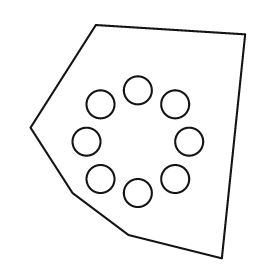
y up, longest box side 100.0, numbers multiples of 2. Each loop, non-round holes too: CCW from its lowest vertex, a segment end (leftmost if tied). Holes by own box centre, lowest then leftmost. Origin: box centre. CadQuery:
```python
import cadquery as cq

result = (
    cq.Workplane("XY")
    .moveTo(36.0, -50.0)
    .lineTo(46.0, 46.0)
    .lineTo(-18.0, 50.0)
    .lineTo(-46.0, 6.0)
    .lineTo(-28.0, -22.0)
    .lineTo(-4.0, -40.0)
    .close()
    .moveTo(0.0, -22.0)
    .circle(6.0)
    .moveTo(-16.0, -16.0)
    .circle(6.0)
    .moveTo(16.0, -16.0)
    .circle(6.0)
    .moveTo(-22.0, 0.0)
    .circle(6.0)
    .moveTo(22.0, 0.0)
    .circle(6.0)
    .moveTo(-16.0, 16.0)
    .circle(6.0)
    .moveTo(16.0, 16.0)
    .circle(6.0)
    .moveTo(0.0, 22.0)
    .circle(6.0)
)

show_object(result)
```